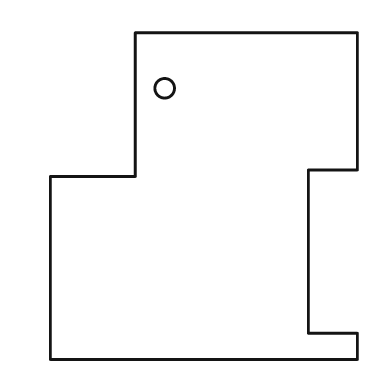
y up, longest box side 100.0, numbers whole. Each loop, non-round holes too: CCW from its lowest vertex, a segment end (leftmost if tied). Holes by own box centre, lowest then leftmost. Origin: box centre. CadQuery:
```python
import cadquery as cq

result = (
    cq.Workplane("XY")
    .moveTo(-47.0, -50.0)
    .lineTo(47.0, -50.0)
    .lineTo(47.0, -42.0)
    .lineTo(32.0, -42.0)
    .lineTo(32.0, 8.0)
    .lineTo(47.0, 8.0)
    .lineTo(47.0, 50.0)
    .lineTo(-21.0, 50.0)
    .lineTo(-21.0, 6.0)
    .lineTo(-47.0, 6.0)
    .close()
    .moveTo(-12.0, 33.0)
    .circle(3.0)
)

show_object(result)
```